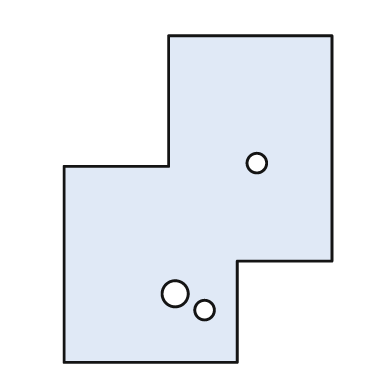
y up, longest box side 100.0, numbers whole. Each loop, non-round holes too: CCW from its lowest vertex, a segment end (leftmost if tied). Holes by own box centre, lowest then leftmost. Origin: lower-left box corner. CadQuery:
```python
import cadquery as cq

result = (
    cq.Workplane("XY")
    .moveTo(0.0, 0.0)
    .lineTo(53.0, 0.0)
    .lineTo(53.0, 31.0)
    .lineTo(82.0, 31.0)
    .lineTo(82.0, 100.0)
    .lineTo(32.0, 100.0)
    .lineTo(32.0, 60.0)
    .lineTo(0.0, 60.0)
    .close()
    .moveTo(43.0, 16.0)
    .circle(3.0)
    .moveTo(34.0, 21.0)
    .circle(4.0)
    .moveTo(59.0, 61.0)
    .circle(3.0)
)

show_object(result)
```